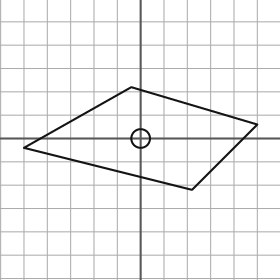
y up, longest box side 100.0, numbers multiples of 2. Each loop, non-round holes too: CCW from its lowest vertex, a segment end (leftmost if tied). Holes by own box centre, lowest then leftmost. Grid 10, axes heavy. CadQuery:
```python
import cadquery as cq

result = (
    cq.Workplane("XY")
    .moveTo(22.0, -22.0)
    .lineTo(50.0, 6.0)
    .lineTo(-4.0, 22.0)
    .lineTo(-50.0, -4.0)
    .close()
    .moveTo(0.0, 0.0)
    .circle(4.0)
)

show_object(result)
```